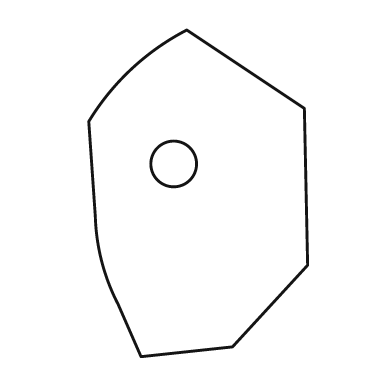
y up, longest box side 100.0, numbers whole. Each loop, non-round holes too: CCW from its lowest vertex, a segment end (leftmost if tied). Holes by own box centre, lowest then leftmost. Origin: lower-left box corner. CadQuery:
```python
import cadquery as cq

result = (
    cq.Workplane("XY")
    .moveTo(16.0, 0.0)
    .lineTo(44.0, 3.0)
    .lineTo(67.0, 28.0)
    .lineTo(66.0, 76.0)
    .lineTo(30.0, 100.0)
    .threePointArc((13.0, 88.0), (0.0, 72.0))
    .lineTo(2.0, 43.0)
    .threePointArc((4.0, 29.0), (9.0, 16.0))
    .close()
    .moveTo(26.0, 59.0)
    .circle(7.0)
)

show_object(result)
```